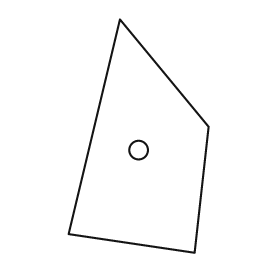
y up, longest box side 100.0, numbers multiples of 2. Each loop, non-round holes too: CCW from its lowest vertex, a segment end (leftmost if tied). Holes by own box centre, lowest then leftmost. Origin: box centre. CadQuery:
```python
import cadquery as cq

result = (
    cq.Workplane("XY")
    .moveTo(24.0, -50.0)
    .lineTo(30.0, 4.0)
    .lineTo(-8.0, 50.0)
    .lineTo(-30.0, -42.0)
    .close()
    .moveTo(0.0, -6.0)
    .circle(4.0)
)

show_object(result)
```